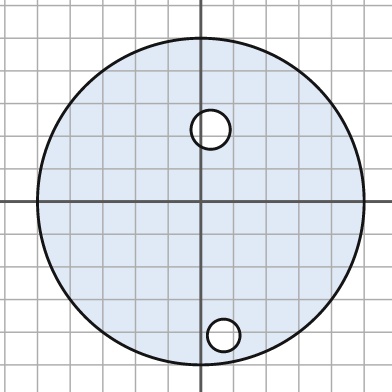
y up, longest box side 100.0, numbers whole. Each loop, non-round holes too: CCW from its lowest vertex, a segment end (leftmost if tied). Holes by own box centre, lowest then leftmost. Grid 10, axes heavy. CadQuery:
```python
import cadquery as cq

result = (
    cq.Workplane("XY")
    .moveTo(0.0, 0.0)
    .circle(50.0)
    .moveTo(7.0, -41.0)
    .circle(5.0)
    .moveTo(3.0, 22.0)
    .circle(6.0)
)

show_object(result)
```